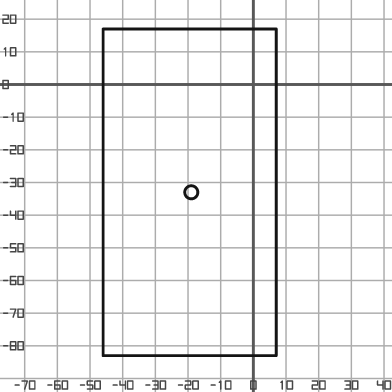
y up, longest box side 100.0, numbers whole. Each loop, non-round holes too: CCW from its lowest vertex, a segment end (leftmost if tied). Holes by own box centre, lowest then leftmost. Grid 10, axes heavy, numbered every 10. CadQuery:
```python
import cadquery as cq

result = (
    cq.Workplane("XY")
    .moveTo(-46.0, -83.0)
    .lineTo(7.0, -83.0)
    .lineTo(7.0, 17.0)
    .lineTo(-46.0, 17.0)
    .close()
    .moveTo(-19.0, -33.0)
    .circle(2.0)
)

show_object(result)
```